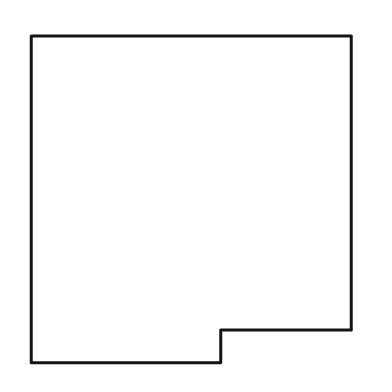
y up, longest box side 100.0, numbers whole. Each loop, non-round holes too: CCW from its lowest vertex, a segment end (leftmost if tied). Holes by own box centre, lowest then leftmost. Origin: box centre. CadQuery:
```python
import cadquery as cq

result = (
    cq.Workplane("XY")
    .moveTo(-49.0, -50.0)
    .lineTo(9.0, -50.0)
    .lineTo(9.0, -40.0)
    .lineTo(49.0, -40.0)
    .lineTo(49.0, 50.0)
    .lineTo(-49.0, 50.0)
    .close()
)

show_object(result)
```